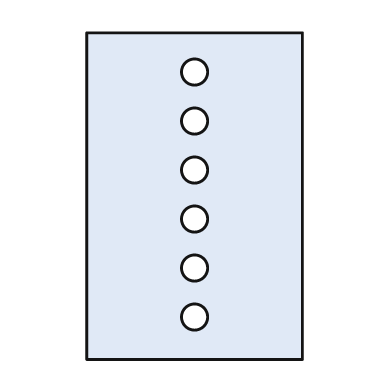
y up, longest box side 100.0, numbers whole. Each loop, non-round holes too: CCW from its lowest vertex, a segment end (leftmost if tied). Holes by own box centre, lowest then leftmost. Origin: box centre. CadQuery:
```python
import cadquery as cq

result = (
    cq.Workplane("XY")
    .moveTo(-33.0, -50.0)
    .lineTo(33.0, -50.0)
    .lineTo(33.0, 50.0)
    .lineTo(-33.0, 50.0)
    .close()
    .moveTo(0.0, -37.0)
    .circle(4.0)
    .moveTo(0.0, -22.0)
    .circle(4.0)
    .moveTo(0.0, -7.0)
    .circle(4.0)
    .moveTo(0.0, 8.0)
    .circle(4.0)
    .moveTo(0.0, 23.0)
    .circle(4.0)
    .moveTo(0.0, 38.0)
    .circle(4.0)
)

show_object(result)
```